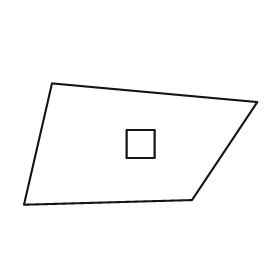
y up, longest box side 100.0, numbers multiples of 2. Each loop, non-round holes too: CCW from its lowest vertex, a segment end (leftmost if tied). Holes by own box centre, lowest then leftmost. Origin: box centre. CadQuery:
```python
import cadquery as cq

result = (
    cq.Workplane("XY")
    .moveTo(-50.0, -26.0)
    .lineTo(22.0, -24.0)
    .lineTo(50.0, 18.0)
    .lineTo(-38.0, 26.0)
    .close()
    .moveTo(-6.0, -6.0)
    .lineTo(6.0, -6.0)
    .lineTo(6.0, 6.0)
    .lineTo(-6.0, 6.0)
    .close()
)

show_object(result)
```